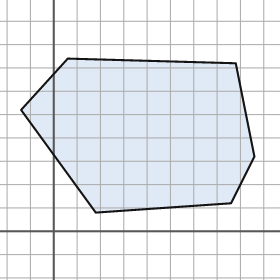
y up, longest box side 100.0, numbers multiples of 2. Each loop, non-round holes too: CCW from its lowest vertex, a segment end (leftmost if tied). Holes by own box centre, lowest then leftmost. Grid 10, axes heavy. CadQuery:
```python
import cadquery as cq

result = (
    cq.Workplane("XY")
    .moveTo(18.0, 8.0)
    .lineTo(76.0, 12.0)
    .lineTo(86.0, 32.0)
    .lineTo(78.0, 72.0)
    .lineTo(6.0, 74.0)
    .lineTo(-14.0, 52.0)
    .close()
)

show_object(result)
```